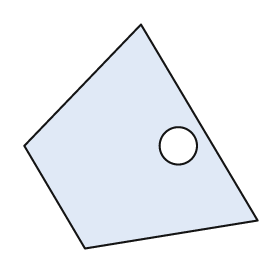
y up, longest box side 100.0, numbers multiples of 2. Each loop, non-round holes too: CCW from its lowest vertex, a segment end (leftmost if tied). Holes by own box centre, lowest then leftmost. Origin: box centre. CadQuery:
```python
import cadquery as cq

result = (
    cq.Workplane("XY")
    .moveTo(-24.0, -48.0)
    .lineTo(50.0, -36.0)
    .lineTo(0.0, 48.0)
    .lineTo(-50.0, -4.0)
    .close()
    .moveTo(16.0, -4.0)
    .circle(8.0)
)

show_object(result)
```